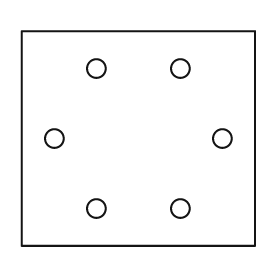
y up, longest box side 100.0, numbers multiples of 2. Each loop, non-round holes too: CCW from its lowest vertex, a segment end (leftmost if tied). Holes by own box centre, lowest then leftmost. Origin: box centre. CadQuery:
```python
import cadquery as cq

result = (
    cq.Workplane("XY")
    .moveTo(-50.0, -46.0)
    .lineTo(50.0, -46.0)
    .lineTo(50.0, 46.0)
    .lineTo(-50.0, 46.0)
    .close()
    .moveTo(-18.0, -30.0)
    .circle(4.0)
    .moveTo(18.0, -30.0)
    .circle(4.0)
    .moveTo(-36.0, 0.0)
    .circle(4.0)
    .moveTo(36.0, 0.0)
    .circle(4.0)
    .moveTo(-18.0, 30.0)
    .circle(4.0)
    .moveTo(18.0, 30.0)
    .circle(4.0)
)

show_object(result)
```